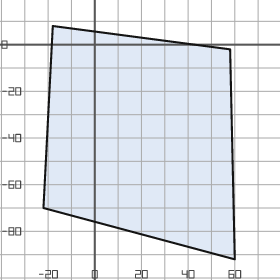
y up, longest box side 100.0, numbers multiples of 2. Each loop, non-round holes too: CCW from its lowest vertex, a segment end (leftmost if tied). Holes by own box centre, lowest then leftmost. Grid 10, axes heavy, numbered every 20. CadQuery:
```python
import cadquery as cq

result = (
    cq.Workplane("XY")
    .moveTo(60.0, -92.0)
    .lineTo(58.0, -2.0)
    .lineTo(-18.0, 8.0)
    .lineTo(-22.0, -70.0)
    .close()
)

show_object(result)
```